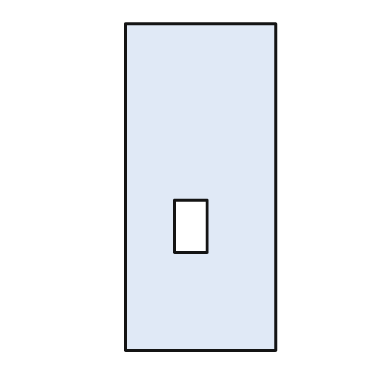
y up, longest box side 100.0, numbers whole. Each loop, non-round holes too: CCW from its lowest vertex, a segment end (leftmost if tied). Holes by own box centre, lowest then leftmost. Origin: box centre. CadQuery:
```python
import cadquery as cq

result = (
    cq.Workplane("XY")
    .moveTo(-23.0, -50.0)
    .lineTo(23.0, -50.0)
    .lineTo(23.0, 50.0)
    .lineTo(-23.0, 50.0)
    .close()
    .moveTo(-8.0, -20.0)
    .lineTo(2.0, -20.0)
    .lineTo(2.0, -4.0)
    .lineTo(-8.0, -4.0)
    .close()
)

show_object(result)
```